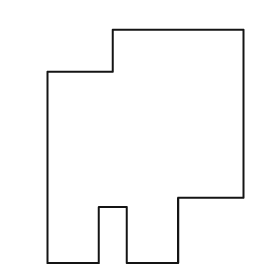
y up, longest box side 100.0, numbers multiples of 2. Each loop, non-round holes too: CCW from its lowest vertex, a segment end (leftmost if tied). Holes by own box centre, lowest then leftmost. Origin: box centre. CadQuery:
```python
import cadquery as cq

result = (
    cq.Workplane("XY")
    .moveTo(-42.0, -50.0)
    .lineTo(-20.0, -50.0)
    .lineTo(-20.0, -26.0)
    .lineTo(-8.0, -26.0)
    .lineTo(-8.0, -50.0)
    .lineTo(14.0, -50.0)
    .lineTo(14.0, -22.0)
    .lineTo(42.0, -22.0)
    .lineTo(42.0, 50.0)
    .lineTo(-14.0, 50.0)
    .lineTo(-14.0, 32.0)
    .lineTo(-42.0, 32.0)
    .close()
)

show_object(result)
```